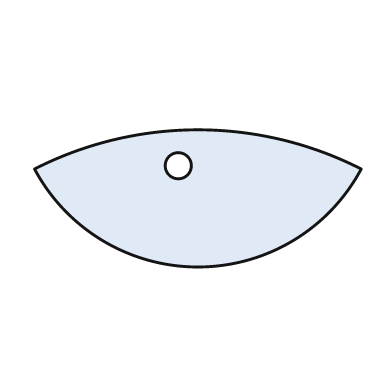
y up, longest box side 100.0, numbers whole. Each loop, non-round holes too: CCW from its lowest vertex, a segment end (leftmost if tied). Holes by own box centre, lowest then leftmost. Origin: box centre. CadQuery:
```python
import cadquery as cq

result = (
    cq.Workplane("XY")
    .moveTo(-50.0, 9.0)
    .threePointArc((0.0, -21.0), (50.0, 9.0))
    .threePointArc((0.0, 21.0), (-50.0, 9.0))
    .close()
    .moveTo(-6.0, 10.0)
    .circle(4.0)
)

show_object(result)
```